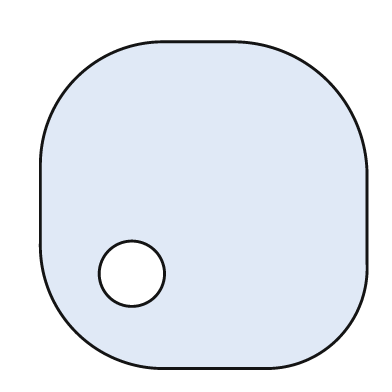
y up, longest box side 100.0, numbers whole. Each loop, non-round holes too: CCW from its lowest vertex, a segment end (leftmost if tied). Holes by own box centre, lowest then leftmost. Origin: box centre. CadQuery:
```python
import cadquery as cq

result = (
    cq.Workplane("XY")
    .moveTo(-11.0, -50.0)
    .lineTo(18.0, -50.0)
    .threePointArc((41.0, -41.0), (50.0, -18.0))
    .lineTo(50.0, 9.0)
    .threePointArc((38.0, 38.0), (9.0, 50.0))
    .lineTo(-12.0, 50.0)
    .threePointArc((-39.0, 39.0), (-50.0, 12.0))
    .lineTo(-50.0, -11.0)
    .threePointArc((-39.0, -39.0), (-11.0, -50.0))
    .close()
    .moveTo(-22.0, -21.0)
    .circle(10.0)
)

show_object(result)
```